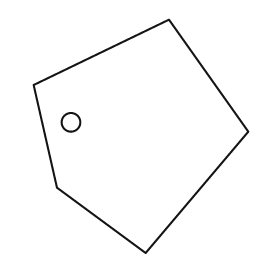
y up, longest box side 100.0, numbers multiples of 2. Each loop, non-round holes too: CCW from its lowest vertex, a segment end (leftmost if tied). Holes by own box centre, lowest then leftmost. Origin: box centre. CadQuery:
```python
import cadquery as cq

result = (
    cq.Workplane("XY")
    .moveTo(2.0, -50.0)
    .lineTo(46.0, 2.0)
    .lineTo(12.0, 50.0)
    .lineTo(-46.0, 22.0)
    .lineTo(-36.0, -22.0)
    .close()
    .moveTo(-30.0, 6.0)
    .circle(4.0)
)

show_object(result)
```